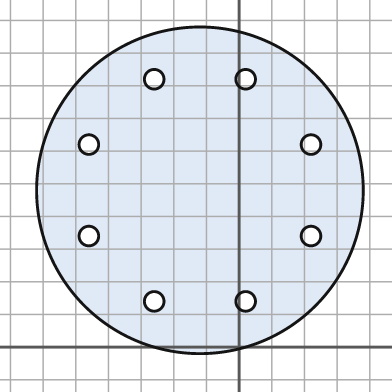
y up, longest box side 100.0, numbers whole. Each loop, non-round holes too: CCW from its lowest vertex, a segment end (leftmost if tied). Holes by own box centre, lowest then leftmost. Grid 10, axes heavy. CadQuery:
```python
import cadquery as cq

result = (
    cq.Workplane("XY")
    .moveTo(-12.0, 48.0)
    .circle(50.0)
    .moveTo(-26.0, 14.0)
    .circle(3.0)
    .moveTo(2.0, 14.0)
    .circle(3.0)
    .moveTo(-46.0, 34.0)
    .circle(3.0)
    .moveTo(22.0, 34.0)
    .circle(3.0)
    .moveTo(-46.0, 62.0)
    .circle(3.0)
    .moveTo(22.0, 62.0)
    .circle(3.0)
    .moveTo(-26.0, 82.0)
    .circle(3.0)
    .moveTo(2.0, 82.0)
    .circle(3.0)
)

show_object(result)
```